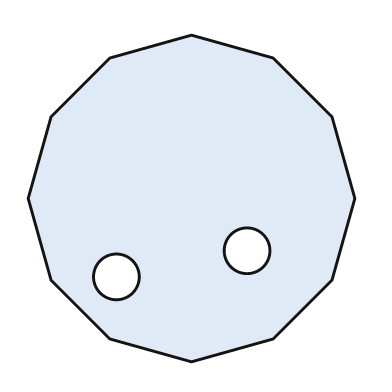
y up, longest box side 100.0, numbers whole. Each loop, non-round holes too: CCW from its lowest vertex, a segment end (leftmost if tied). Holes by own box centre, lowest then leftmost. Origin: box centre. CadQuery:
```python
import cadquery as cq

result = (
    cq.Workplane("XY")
    .moveTo(0.0, -50.0)
    .lineTo(25.0, -43.0)
    .lineTo(43.0, -25.0)
    .lineTo(50.0, 0.0)
    .lineTo(43.0, 25.0)
    .lineTo(25.0, 43.0)
    .lineTo(0.0, 50.0)
    .lineTo(-25.0, 43.0)
    .lineTo(-43.0, 25.0)
    .lineTo(-50.0, 0.0)
    .lineTo(-43.0, -25.0)
    .lineTo(-25.0, -43.0)
    .close()
    .moveTo(-23.0, -24.0)
    .circle(7.0)
    .moveTo(17.0, -16.0)
    .circle(7.0)
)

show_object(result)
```